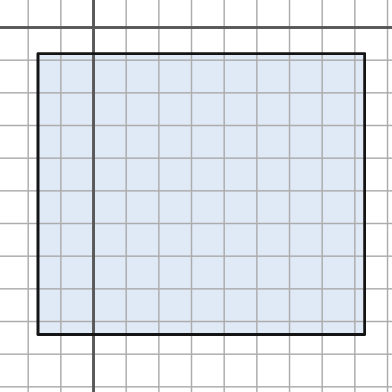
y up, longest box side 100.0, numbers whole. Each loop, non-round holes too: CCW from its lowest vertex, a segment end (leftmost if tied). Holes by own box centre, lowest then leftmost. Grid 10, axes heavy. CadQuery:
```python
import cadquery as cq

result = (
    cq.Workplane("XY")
    .moveTo(-17.0, -94.0)
    .lineTo(83.0, -94.0)
    .lineTo(83.0, -8.0)
    .lineTo(-17.0, -8.0)
    .close()
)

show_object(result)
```